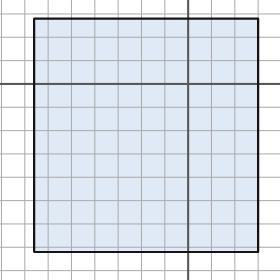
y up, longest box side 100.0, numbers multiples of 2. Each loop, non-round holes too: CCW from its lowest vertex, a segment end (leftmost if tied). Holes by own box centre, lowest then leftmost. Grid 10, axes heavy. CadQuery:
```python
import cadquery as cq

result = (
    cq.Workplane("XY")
    .moveTo(-66.0, -72.0)
    .lineTo(30.0, -72.0)
    .lineTo(30.0, 28.0)
    .lineTo(-66.0, 28.0)
    .close()
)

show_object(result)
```